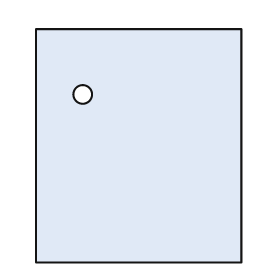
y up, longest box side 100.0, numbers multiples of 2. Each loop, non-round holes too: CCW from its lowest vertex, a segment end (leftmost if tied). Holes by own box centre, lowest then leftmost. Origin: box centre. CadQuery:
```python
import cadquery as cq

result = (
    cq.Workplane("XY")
    .moveTo(-44.0, -50.0)
    .lineTo(44.0, -50.0)
    .lineTo(44.0, 50.0)
    .lineTo(-44.0, 50.0)
    .close()
    .moveTo(-24.0, 22.0)
    .circle(4.0)
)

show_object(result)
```